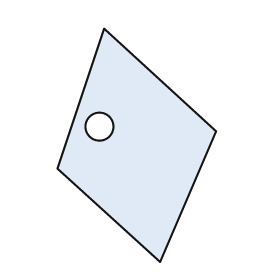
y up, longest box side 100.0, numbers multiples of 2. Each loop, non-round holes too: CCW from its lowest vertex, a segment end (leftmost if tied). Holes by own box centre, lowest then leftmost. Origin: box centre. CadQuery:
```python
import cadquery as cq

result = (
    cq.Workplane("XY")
    .moveTo(10.0, -50.0)
    .lineTo(34.0, 6.0)
    .lineTo(-14.0, 50.0)
    .lineTo(-34.0, -10.0)
    .close()
    .moveTo(-16.0, 8.0)
    .circle(6.0)
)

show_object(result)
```